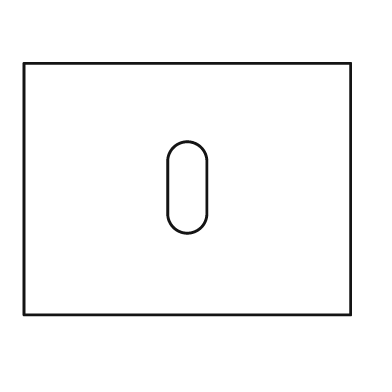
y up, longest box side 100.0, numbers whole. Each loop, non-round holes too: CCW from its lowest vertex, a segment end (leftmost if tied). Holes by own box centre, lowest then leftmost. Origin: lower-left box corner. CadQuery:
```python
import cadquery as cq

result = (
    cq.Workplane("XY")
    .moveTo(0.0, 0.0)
    .lineTo(100.0, 0.0)
    .lineTo(100.0, 77.0)
    .lineTo(0.0, 77.0)
    .close()
    .moveTo(44.0, 31.0)
    .threePointArc((50.0, 25.0), (56.0, 31.0))
    .lineTo(56.0, 47.0)
    .threePointArc((50.0, 53.0), (44.0, 47.0))
    .close()
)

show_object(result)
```